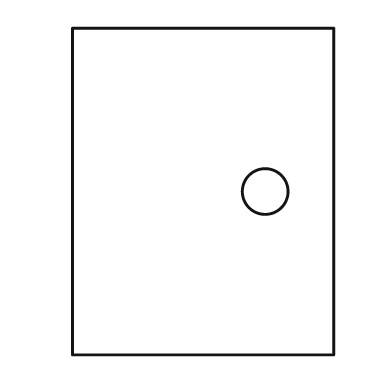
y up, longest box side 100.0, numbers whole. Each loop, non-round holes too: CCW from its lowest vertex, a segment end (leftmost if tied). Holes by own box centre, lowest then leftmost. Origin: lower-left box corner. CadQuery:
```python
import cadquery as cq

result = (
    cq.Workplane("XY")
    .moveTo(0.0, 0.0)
    .lineTo(80.0, 0.0)
    .lineTo(80.0, 100.0)
    .lineTo(0.0, 100.0)
    .close()
    .moveTo(59.0, 50.0)
    .circle(7.0)
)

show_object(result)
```